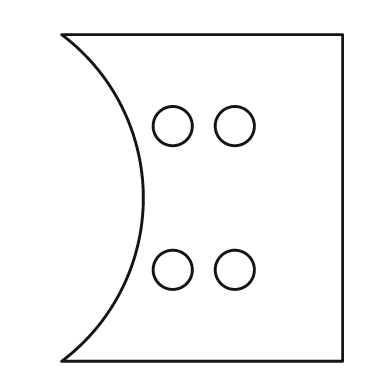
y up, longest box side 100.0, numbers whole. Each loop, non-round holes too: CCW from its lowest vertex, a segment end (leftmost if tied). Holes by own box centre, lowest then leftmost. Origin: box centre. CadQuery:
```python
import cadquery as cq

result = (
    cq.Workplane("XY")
    .moveTo(-43.0, -50.0)
    .lineTo(43.0, -50.0)
    .lineTo(43.0, 50.0)
    .lineTo(-43.0, 50.0)
    .threePointArc((-18.0, 0.0), (-43.0, -50.0))
    .close()
    .moveTo(-9.0, -22.0)
    .circle(6.0)
    .moveTo(10.0, -22.0)
    .circle(6.0)
    .moveTo(-9.0, 22.0)
    .circle(6.0)
    .moveTo(10.0, 22.0)
    .circle(6.0)
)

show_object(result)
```